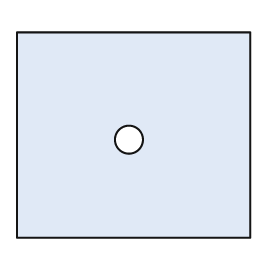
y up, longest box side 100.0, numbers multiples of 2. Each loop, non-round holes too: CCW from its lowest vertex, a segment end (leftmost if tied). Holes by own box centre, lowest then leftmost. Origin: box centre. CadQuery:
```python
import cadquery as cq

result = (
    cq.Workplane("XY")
    .moveTo(-50.0, -44.0)
    .lineTo(50.0, -44.0)
    .lineTo(50.0, 44.0)
    .lineTo(-50.0, 44.0)
    .close()
    .moveTo(-2.0, -2.0)
    .circle(6.0)
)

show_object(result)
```